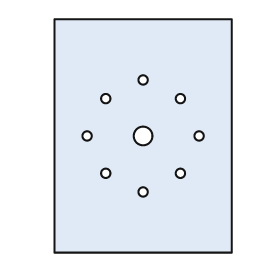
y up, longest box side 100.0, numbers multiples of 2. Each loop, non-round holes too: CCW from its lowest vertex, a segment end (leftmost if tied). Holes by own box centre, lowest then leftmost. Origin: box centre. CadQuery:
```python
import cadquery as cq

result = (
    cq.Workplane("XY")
    .moveTo(-38.0, -50.0)
    .lineTo(38.0, -50.0)
    .lineTo(38.0, 50.0)
    .lineTo(-38.0, 50.0)
    .close()
    .moveTo(0.0, -24.0)
    .circle(2.0)
    .moveTo(-16.0, -16.0)
    .circle(2.0)
    .moveTo(16.0, -16.0)
    .circle(2.0)
    .moveTo(-24.0, 0.0)
    .circle(2.0)
    .moveTo(0.0, 0.0)
    .circle(4.0)
    .moveTo(24.0, 0.0)
    .circle(2.0)
    .moveTo(-16.0, 16.0)
    .circle(2.0)
    .moveTo(16.0, 16.0)
    .circle(2.0)
    .moveTo(0.0, 24.0)
    .circle(2.0)
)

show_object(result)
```